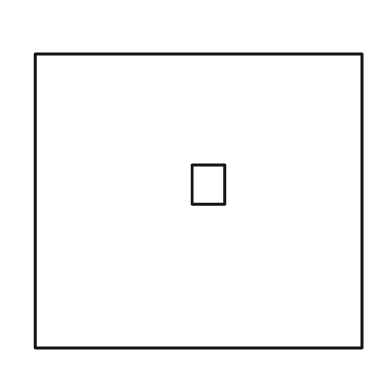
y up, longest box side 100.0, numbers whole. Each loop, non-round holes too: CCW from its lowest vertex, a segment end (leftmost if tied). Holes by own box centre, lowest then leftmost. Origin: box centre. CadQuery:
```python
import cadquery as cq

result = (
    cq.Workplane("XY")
    .moveTo(-50.0, -45.0)
    .lineTo(50.0, -45.0)
    .lineTo(50.0, 45.0)
    .lineTo(-50.0, 45.0)
    .close()
    .moveTo(-2.0, -1.0)
    .lineTo(8.0, -1.0)
    .lineTo(8.0, 11.0)
    .lineTo(-2.0, 11.0)
    .close()
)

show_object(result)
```